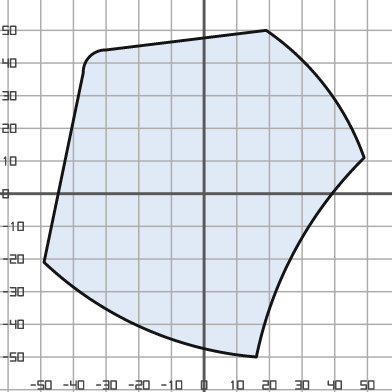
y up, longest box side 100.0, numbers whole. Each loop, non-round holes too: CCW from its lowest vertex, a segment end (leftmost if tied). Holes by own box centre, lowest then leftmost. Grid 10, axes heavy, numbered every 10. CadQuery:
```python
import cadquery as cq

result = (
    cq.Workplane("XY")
    .moveTo(16.0, -50.0)
    .threePointArc((28.0, -17.0), (49.0, 11.0))
    .threePointArc((37.0, 33.0), (19.0, 50.0))
    .lineTo(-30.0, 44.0)
    .threePointArc((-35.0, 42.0), (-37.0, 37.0))
    .lineTo(-49.0, -21.0)
    .threePointArc((-19.0, -41.0), (16.0, -50.0))
    .close()
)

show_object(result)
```